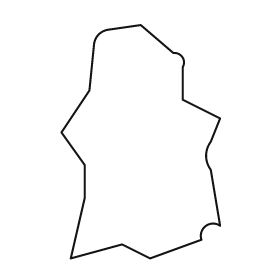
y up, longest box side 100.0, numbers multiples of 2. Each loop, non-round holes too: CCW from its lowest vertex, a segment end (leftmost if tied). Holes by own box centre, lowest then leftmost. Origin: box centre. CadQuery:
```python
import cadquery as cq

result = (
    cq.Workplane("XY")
    .moveTo(-30.0, -50.0)
    .lineTo(-8.0, -44.0)
    .lineTo(4.0, -50.0)
    .lineTo(26.0, -42.0)
    .threePointArc((28.0, -36.0), (34.0, -36.0))
    .lineTo(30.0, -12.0)
    .threePointArc((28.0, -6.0), (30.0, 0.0))
    .lineTo(34.0, 10.0)
    .lineTo(18.0, 18.0)
    .lineTo(18.0, 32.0)
    .threePointArc((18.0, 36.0), (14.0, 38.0))
    .lineTo(0.0, 50.0)
    .lineTo(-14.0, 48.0)
    .threePointArc((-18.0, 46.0), (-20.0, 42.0))
    .lineTo(-22.0, 22.0)
    .lineTo(-34.0, 4.0)
    .lineTo(-24.0, -10.0)
    .lineTo(-24.0, -24.0)
    .close()
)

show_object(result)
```